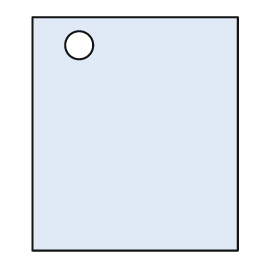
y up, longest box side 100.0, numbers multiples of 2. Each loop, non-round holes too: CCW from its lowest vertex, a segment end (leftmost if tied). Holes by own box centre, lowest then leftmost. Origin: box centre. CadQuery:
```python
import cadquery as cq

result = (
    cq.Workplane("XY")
    .moveTo(-44.0, -50.0)
    .lineTo(44.0, -50.0)
    .lineTo(44.0, 50.0)
    .lineTo(-44.0, 50.0)
    .close()
    .moveTo(-24.0, 38.0)
    .circle(6.0)
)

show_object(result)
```